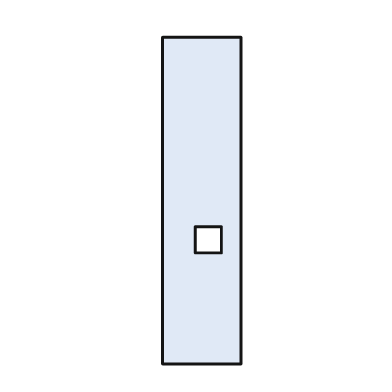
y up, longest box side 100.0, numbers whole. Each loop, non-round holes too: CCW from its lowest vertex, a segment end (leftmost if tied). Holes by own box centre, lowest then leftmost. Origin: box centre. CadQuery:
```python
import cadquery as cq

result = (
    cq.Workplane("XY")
    .moveTo(-12.0, -50.0)
    .lineTo(12.0, -50.0)
    .lineTo(12.0, 50.0)
    .lineTo(-12.0, 50.0)
    .close()
    .moveTo(-2.0, -16.0)
    .lineTo(6.0, -16.0)
    .lineTo(6.0, -8.0)
    .lineTo(-2.0, -8.0)
    .close()
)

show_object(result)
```